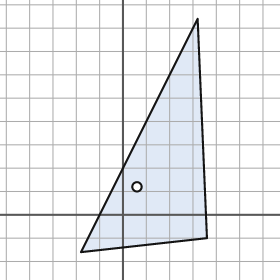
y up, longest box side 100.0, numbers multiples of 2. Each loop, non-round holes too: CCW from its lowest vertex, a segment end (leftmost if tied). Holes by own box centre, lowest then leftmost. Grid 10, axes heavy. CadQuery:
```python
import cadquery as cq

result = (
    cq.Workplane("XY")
    .moveTo(-18.0, -16.0)
    .lineTo(36.0, -10.0)
    .lineTo(32.0, 84.0)
    .close()
    .moveTo(6.0, 12.0)
    .circle(2.0)
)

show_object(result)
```